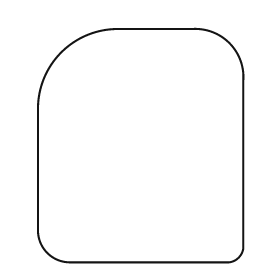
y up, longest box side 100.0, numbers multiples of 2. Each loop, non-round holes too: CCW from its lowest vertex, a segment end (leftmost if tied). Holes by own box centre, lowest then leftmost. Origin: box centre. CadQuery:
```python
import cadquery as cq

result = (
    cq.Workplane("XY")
    .moveTo(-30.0, -50.0)
    .lineTo(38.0, -50.0)
    .threePointArc((42.0, -48.0), (44.0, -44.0))
    .lineTo(44.0, 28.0)
    .threePointArc((38.0, 44.0), (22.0, 50.0))
    .lineTo(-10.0, 50.0)
    .threePointArc((-34.0, 40.0), (-44.0, 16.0))
    .lineTo(-44.0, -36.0)
    .threePointArc((-40.0, -46.0), (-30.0, -50.0))
    .close()
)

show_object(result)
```